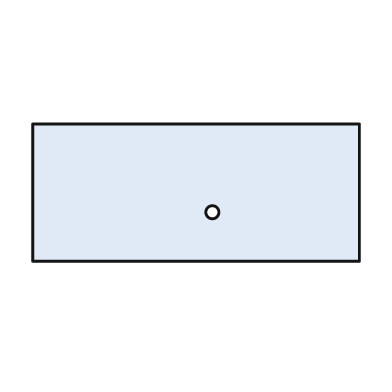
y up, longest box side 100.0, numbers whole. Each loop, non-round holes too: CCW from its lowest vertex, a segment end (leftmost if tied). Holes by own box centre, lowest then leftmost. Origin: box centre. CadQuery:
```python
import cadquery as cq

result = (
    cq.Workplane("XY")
    .moveTo(-50.0, -21.0)
    .lineTo(50.0, -21.0)
    .lineTo(50.0, 21.0)
    .lineTo(-50.0, 21.0)
    .close()
    .moveTo(5.0, -6.0)
    .circle(2.0)
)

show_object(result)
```